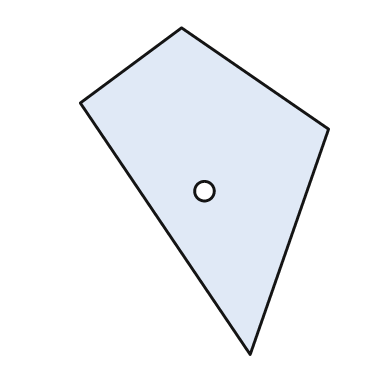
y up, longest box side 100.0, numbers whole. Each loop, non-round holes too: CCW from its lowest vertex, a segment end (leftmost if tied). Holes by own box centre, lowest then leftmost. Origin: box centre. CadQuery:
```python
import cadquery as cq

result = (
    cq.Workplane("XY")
    .moveTo(14.0, -50.0)
    .lineTo(38.0, 19.0)
    .lineTo(-7.0, 50.0)
    .lineTo(-38.0, 27.0)
    .close()
    .moveTo(0.0, 0.0)
    .circle(3.0)
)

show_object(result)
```